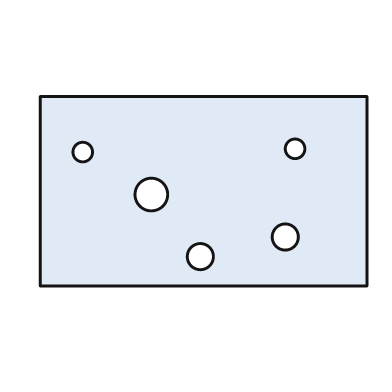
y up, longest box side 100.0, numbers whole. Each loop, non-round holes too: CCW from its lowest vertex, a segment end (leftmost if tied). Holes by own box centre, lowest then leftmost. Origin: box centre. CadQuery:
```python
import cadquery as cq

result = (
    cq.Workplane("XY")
    .moveTo(-50.0, -29.0)
    .lineTo(50.0, -29.0)
    .lineTo(50.0, 29.0)
    .lineTo(-50.0, 29.0)
    .close()
    .moveTo(-1.0, -20.0)
    .circle(4.0)
    .moveTo(25.0, -14.0)
    .circle(4.0)
    .moveTo(-16.0, -1.0)
    .circle(5.0)
    .moveTo(-37.0, 12.0)
    .circle(3.0)
    .moveTo(28.0, 13.0)
    .circle(3.0)
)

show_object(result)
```